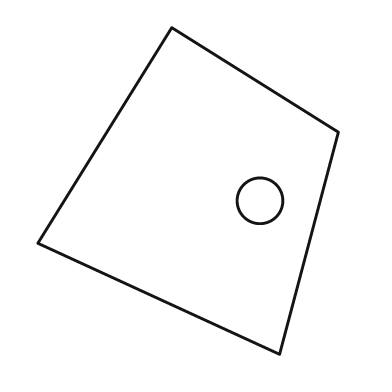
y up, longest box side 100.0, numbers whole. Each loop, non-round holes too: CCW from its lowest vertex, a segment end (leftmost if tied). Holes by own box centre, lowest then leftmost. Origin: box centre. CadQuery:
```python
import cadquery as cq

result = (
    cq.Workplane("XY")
    .moveTo(28.0, -50.0)
    .lineTo(46.0, 18.0)
    .lineTo(-5.0, 50.0)
    .lineTo(-46.0, -16.0)
    .close()
    .moveTo(22.0, -3.0)
    .circle(7.0)
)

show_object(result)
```